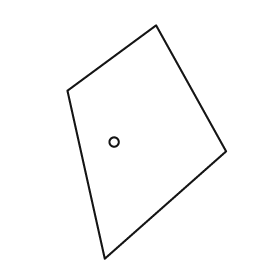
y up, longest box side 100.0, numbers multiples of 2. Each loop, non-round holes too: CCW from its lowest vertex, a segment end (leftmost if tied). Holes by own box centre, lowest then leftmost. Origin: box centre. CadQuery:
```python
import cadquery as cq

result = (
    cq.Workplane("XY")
    .moveTo(-18.0, -50.0)
    .lineTo(34.0, -4.0)
    .lineTo(4.0, 50.0)
    .lineTo(-34.0, 22.0)
    .close()
    .moveTo(-14.0, 0.0)
    .circle(2.0)
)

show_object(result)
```